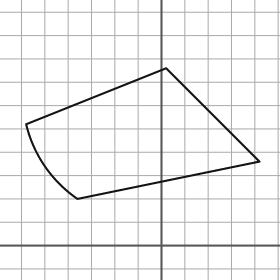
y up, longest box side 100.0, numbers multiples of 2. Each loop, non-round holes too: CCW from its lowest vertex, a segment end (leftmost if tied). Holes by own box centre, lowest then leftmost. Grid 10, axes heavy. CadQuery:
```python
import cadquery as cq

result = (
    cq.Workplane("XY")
    .moveTo(-36.0, 20.0)
    .lineTo(42.0, 36.0)
    .lineTo(2.0, 76.0)
    .lineTo(-58.0, 52.0)
    .threePointArc((-50.0, 34.0), (-36.0, 20.0))
    .close()
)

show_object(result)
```